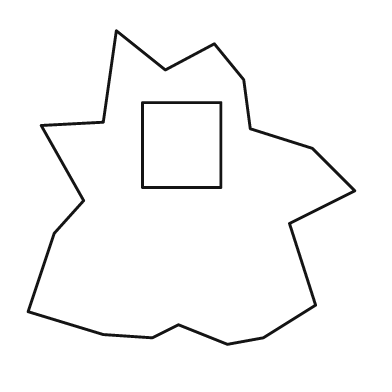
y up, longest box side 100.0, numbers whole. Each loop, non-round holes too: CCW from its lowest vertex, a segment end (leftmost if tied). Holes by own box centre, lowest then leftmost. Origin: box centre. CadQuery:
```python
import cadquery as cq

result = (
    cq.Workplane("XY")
    .moveTo(11.0, -48.0)
    .lineTo(22.0, -46.0)
    .lineTo(38.0, -36.0)
    .lineTo(30.0, -11.0)
    .lineTo(50.0, -1.0)
    .lineTo(37.0, 12.0)
    .lineTo(18.0, 18.0)
    .lineTo(16.0, 33.0)
    .lineTo(7.0, 44.0)
    .lineTo(-8.0, 36.0)
    .lineTo(-23.0, 48.0)
    .lineTo(-27.0, 20.0)
    .lineTo(-46.0, 19.0)
    .lineTo(-33.0, -4.0)
    .lineTo(-42.0, -14.0)
    .lineTo(-50.0, -38.0)
    .lineTo(-27.0, -45.0)
    .lineTo(-12.0, -46.0)
    .lineTo(-4.0, -42.0)
    .close()
    .moveTo(-15.0, 0.0)
    .lineTo(9.0, 0.0)
    .lineTo(9.0, 26.0)
    .lineTo(-15.0, 26.0)
    .close()
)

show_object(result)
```